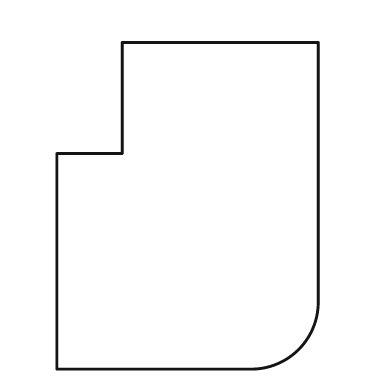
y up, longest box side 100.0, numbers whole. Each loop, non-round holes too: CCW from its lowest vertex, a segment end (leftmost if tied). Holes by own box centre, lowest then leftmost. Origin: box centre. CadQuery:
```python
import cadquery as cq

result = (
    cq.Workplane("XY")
    .moveTo(-40.0, -50.0)
    .lineTo(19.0, -50.0)
    .threePointArc((34.0, -44.0), (40.0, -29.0))
    .lineTo(40.0, 50.0)
    .lineTo(-20.0, 50.0)
    .lineTo(-20.0, 16.0)
    .lineTo(-40.0, 16.0)
    .close()
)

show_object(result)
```